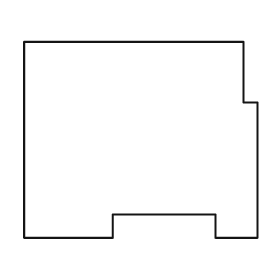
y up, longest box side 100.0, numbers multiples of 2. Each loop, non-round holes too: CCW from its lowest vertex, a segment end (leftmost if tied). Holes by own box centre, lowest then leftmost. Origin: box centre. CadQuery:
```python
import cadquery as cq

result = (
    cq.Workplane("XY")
    .moveTo(-50.0, -42.0)
    .lineTo(-12.0, -42.0)
    .lineTo(-12.0, -32.0)
    .lineTo(32.0, -32.0)
    .lineTo(32.0, -42.0)
    .lineTo(50.0, -42.0)
    .lineTo(50.0, 16.0)
    .lineTo(44.0, 16.0)
    .lineTo(44.0, 42.0)
    .lineTo(-50.0, 42.0)
    .close()
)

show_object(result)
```